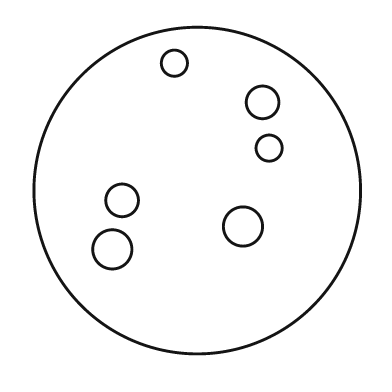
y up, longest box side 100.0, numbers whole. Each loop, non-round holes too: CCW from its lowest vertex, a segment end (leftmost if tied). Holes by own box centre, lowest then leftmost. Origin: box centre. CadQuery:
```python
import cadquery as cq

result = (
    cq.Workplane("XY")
    .moveTo(0.0, 0.0)
    .circle(50.0)
    .moveTo(-26.0, -18.0)
    .circle(6.0)
    .moveTo(14.0, -11.0)
    .circle(6.0)
    .moveTo(-23.0, -3.0)
    .circle(5.0)
    .moveTo(22.0, 13.0)
    .circle(4.0)
    .moveTo(20.0, 27.0)
    .circle(5.0)
    .moveTo(-7.0, 39.0)
    .circle(4.0)
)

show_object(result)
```